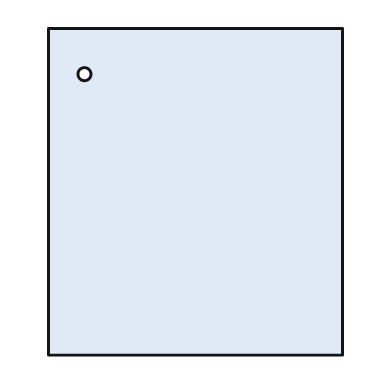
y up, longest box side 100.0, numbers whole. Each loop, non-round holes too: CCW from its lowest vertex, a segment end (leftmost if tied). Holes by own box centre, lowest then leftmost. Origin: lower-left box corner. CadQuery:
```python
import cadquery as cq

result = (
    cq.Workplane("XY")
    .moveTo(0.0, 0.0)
    .lineTo(90.0, 0.0)
    .lineTo(90.0, 100.0)
    .lineTo(0.0, 100.0)
    .close()
    .moveTo(11.0, 86.0)
    .circle(2.0)
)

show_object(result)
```